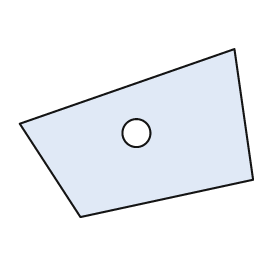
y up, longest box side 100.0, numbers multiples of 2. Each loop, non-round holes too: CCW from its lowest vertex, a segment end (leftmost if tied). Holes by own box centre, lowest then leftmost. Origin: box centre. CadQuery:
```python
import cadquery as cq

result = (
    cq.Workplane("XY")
    .moveTo(-24.0, -36.0)
    .lineTo(50.0, -20.0)
    .lineTo(42.0, 36.0)
    .lineTo(-50.0, 4.0)
    .close()
    .moveTo(0.0, 0.0)
    .circle(6.0)
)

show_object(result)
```